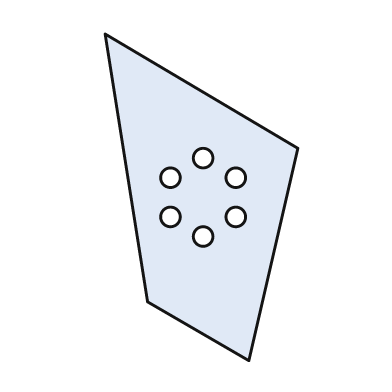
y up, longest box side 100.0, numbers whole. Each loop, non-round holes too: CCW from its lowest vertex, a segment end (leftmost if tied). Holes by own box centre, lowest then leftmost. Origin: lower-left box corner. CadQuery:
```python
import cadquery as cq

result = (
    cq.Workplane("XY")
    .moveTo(44.0, 0.0)
    .lineTo(59.0, 65.0)
    .lineTo(0.0, 100.0)
    .lineTo(13.0, 18.0)
    .close()
    .moveTo(30.0, 38.0)
    .circle(3.0)
    .moveTo(20.0, 44.0)
    .circle(3.0)
    .moveTo(40.0, 44.0)
    .circle(3.0)
    .moveTo(20.0, 56.0)
    .circle(3.0)
    .moveTo(40.0, 56.0)
    .circle(3.0)
    .moveTo(30.0, 62.0)
    .circle(3.0)
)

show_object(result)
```